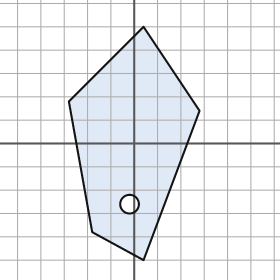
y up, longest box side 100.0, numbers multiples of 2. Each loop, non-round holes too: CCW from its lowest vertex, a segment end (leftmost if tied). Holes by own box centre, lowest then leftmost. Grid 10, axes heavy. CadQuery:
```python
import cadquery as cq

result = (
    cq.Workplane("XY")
    .moveTo(4.0, -50.0)
    .lineTo(28.0, 14.0)
    .lineTo(4.0, 50.0)
    .lineTo(-28.0, 18.0)
    .lineTo(-18.0, -38.0)
    .close()
    .moveTo(-2.0, -26.0)
    .circle(4.0)
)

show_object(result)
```